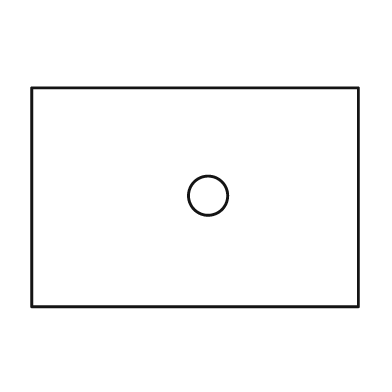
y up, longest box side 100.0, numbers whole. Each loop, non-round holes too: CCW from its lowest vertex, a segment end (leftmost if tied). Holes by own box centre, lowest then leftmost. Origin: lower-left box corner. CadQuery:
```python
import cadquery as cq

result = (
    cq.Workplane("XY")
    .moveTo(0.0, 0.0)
    .lineTo(100.0, 0.0)
    .lineTo(100.0, 67.0)
    .lineTo(0.0, 67.0)
    .close()
    .moveTo(54.0, 34.0)
    .circle(6.0)
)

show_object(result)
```